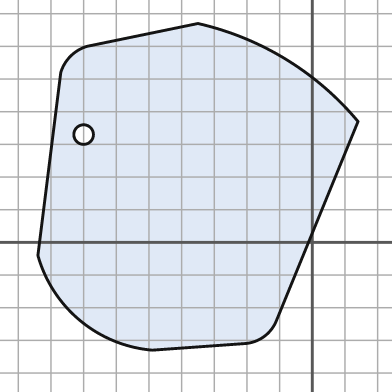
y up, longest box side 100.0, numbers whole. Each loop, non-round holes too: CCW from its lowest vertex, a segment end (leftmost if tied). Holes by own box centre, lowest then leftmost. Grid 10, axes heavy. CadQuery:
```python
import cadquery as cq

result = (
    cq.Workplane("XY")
    .moveTo(-49.0, -33.0)
    .lineTo(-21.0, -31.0)
    .threePointArc((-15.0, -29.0), (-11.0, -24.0))
    .lineTo(14.0, 37.0)
    .threePointArc((-8.0, 56.0), (-35.0, 67.0))
    .lineTo(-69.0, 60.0)
    .threePointArc((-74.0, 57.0), (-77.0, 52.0))
    .lineTo(-84.0, -4.0)
    .threePointArc((-71.0, -24.0), (-49.0, -33.0))
    .close()
    .moveTo(-70.0, 33.0)
    .circle(3.0)
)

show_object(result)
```